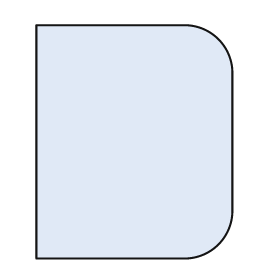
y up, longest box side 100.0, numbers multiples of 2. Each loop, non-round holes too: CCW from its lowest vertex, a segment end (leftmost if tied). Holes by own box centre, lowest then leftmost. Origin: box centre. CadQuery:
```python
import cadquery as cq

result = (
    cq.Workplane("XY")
    .moveTo(-42.0, -50.0)
    .lineTo(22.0, -50.0)
    .threePointArc((36.0, -44.0), (42.0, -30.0))
    .lineTo(42.0, 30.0)
    .threePointArc((36.0, 44.0), (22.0, 50.0))
    .lineTo(-42.0, 50.0)
    .close()
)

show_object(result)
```